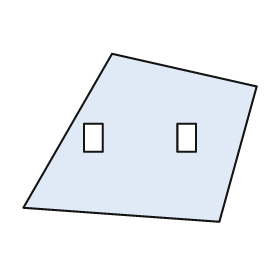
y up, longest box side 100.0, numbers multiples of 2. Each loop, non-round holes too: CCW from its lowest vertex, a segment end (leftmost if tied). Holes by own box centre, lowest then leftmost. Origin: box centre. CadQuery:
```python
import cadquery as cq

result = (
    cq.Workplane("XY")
    .moveTo(34.0, -36.0)
    .lineTo(50.0, 22.0)
    .lineTo(-12.0, 36.0)
    .lineTo(-50.0, -30.0)
    .close()
    .moveTo(-24.0, -6.0)
    .lineTo(-16.0, -6.0)
    .lineTo(-16.0, 6.0)
    .lineTo(-24.0, 6.0)
    .close()
    .moveTo(16.0, -6.0)
    .lineTo(24.0, -6.0)
    .lineTo(24.0, 6.0)
    .lineTo(16.0, 6.0)
    .close()
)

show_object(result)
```